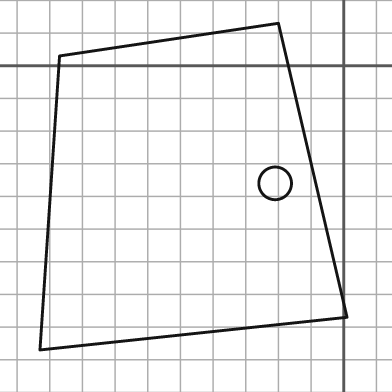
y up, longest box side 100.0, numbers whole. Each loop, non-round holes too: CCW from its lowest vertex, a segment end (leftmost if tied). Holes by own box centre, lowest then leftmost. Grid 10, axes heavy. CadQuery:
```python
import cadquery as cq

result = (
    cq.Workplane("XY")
    .moveTo(-93.0, -87.0)
    .lineTo(1.0, -77.0)
    .lineTo(-20.0, 13.0)
    .lineTo(-87.0, 3.0)
    .close()
    .moveTo(-21.0, -36.0)
    .circle(5.0)
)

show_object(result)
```